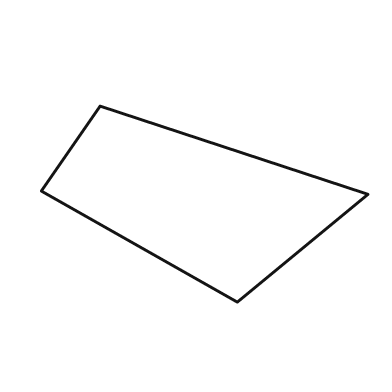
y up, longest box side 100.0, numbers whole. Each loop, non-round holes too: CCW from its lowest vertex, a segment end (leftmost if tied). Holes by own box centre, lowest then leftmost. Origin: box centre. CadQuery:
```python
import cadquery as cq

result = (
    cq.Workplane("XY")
    .moveTo(10.0, -30.0)
    .lineTo(50.0, 3.0)
    .lineTo(-32.0, 30.0)
    .lineTo(-50.0, 4.0)
    .close()
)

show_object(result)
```